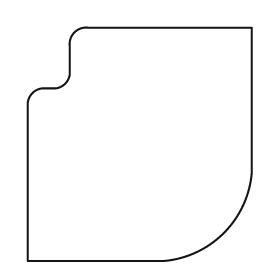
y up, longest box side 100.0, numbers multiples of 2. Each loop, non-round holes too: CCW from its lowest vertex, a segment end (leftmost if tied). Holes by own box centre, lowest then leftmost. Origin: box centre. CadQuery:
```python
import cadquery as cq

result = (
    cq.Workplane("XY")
    .moveTo(-48.0, -50.0)
    .lineTo(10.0, -50.0)
    .threePointArc((36.0, -38.0), (48.0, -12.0))
    .lineTo(48.0, 50.0)
    .lineTo(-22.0, 50.0)
    .threePointArc((-28.0, 48.0), (-30.0, 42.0))
    .lineTo(-30.0, 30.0)
    .threePointArc((-32.0, 26.0), (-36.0, 24.0))
    .lineTo(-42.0, 24.0)
    .threePointArc((-46.0, 22.0), (-48.0, 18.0))
    .close()
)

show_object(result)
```